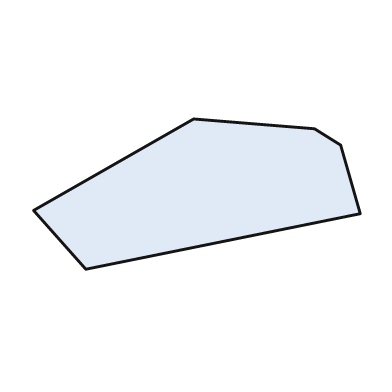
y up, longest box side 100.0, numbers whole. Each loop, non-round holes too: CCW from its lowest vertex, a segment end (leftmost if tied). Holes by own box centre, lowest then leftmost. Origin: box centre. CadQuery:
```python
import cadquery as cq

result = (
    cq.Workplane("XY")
    .moveTo(-34.0, -23.0)
    .lineTo(50.0, -6.0)
    .lineTo(44.0, 15.0)
    .lineTo(36.0, 20.0)
    .lineTo(-1.0, 23.0)
    .lineTo(-50.0, -5.0)
    .close()
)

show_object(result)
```